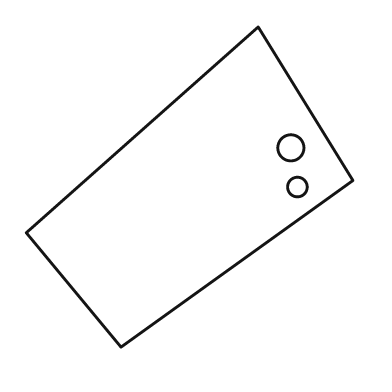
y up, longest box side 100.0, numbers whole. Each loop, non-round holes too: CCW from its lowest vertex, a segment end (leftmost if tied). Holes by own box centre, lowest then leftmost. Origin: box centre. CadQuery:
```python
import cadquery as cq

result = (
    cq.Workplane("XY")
    .moveTo(-21.0, -49.0)
    .lineTo(50.0, 2.0)
    .lineTo(21.0, 49.0)
    .lineTo(-50.0, -14.0)
    .close()
    .moveTo(33.0, 0.0)
    .circle(3.0)
    .moveTo(31.0, 12.0)
    .circle(4.0)
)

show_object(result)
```